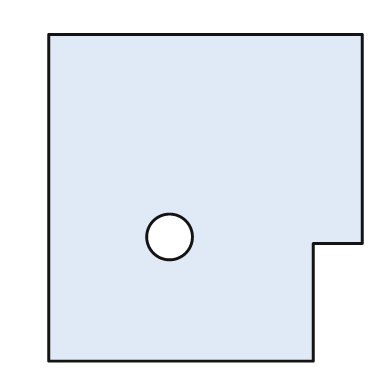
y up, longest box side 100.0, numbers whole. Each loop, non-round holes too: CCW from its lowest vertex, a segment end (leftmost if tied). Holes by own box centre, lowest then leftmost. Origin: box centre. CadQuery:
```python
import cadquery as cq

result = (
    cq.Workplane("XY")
    .moveTo(-48.0, -50.0)
    .lineTo(33.0, -50.0)
    .lineTo(33.0, -14.0)
    .lineTo(48.0, -14.0)
    .lineTo(48.0, 50.0)
    .lineTo(-48.0, 50.0)
    .close()
    .moveTo(-11.0, -12.0)
    .circle(7.0)
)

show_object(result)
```